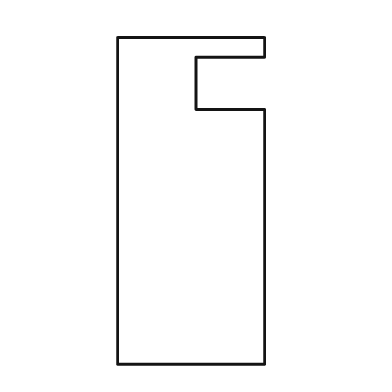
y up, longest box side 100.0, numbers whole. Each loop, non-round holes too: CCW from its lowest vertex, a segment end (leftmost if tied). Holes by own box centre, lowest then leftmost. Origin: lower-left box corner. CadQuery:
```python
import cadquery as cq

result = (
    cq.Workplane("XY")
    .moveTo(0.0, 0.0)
    .lineTo(45.0, 0.0)
    .lineTo(45.0, 78.0)
    .lineTo(24.0, 78.0)
    .lineTo(24.0, 94.0)
    .lineTo(45.0, 94.0)
    .lineTo(45.0, 100.0)
    .lineTo(0.0, 100.0)
    .close()
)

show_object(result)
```